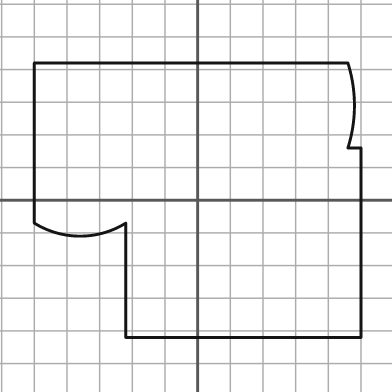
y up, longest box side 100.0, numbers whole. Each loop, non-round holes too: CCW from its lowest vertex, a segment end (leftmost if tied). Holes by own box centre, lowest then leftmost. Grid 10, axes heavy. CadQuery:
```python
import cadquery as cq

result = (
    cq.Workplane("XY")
    .moveTo(-22.0, -42.0)
    .lineTo(50.0, -42.0)
    .lineTo(50.0, 16.0)
    .lineTo(46.0, 16.0)
    .threePointArc((48.0, 29.0), (46.0, 42.0))
    .lineTo(-50.0, 42.0)
    .lineTo(-50.0, -7.0)
    .threePointArc((-36.0, -11.0), (-22.0, -7.0))
    .close()
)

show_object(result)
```